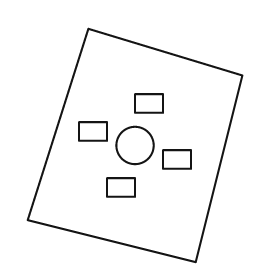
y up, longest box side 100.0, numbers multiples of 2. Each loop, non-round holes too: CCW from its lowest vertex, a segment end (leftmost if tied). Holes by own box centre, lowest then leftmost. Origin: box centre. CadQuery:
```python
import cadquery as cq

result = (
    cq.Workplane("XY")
    .moveTo(26.0, -50.0)
    .lineTo(46.0, 30.0)
    .lineTo(-20.0, 50.0)
    .lineTo(-46.0, -32.0)
    .close()
    .moveTo(-12.0, -22.0)
    .lineTo(0.0, -22.0)
    .lineTo(0.0, -14.0)
    .lineTo(-12.0, -14.0)
    .close()
    .moveTo(12.0, -10.0)
    .lineTo(24.0, -10.0)
    .lineTo(24.0, -2.0)
    .lineTo(12.0, -2.0)
    .close()
    .moveTo(0.0, 0.0)
    .circle(8.0)
    .moveTo(-24.0, 2.0)
    .lineTo(-12.0, 2.0)
    .lineTo(-12.0, 10.0)
    .lineTo(-24.0, 10.0)
    .close()
    .moveTo(0.0, 14.0)
    .lineTo(12.0, 14.0)
    .lineTo(12.0, 22.0)
    .lineTo(0.0, 22.0)
    .close()
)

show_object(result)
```